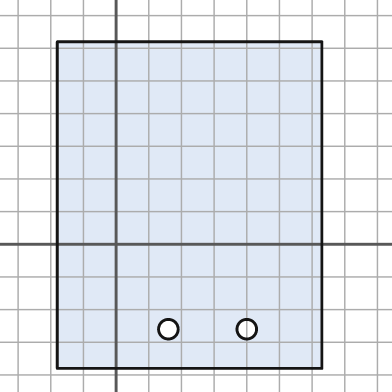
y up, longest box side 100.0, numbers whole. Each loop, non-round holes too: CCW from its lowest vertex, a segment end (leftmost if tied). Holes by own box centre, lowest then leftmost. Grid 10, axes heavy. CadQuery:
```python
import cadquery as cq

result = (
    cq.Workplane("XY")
    .moveTo(-18.0, -38.0)
    .lineTo(63.0, -38.0)
    .lineTo(63.0, 62.0)
    .lineTo(-18.0, 62.0)
    .close()
    .moveTo(16.0, -26.0)
    .circle(3.0)
    .moveTo(40.0, -26.0)
    .circle(3.0)
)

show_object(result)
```